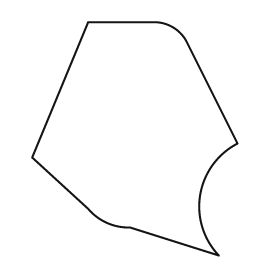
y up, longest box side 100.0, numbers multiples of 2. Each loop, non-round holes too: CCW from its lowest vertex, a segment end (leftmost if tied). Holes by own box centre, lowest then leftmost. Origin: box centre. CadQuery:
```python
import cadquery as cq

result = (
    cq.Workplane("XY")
    .moveTo(36.0, -50.0)
    .threePointArc((28.0, -24.0), (44.0, -2.0))
    .lineTo(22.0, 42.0)
    .threePointArc((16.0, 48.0), (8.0, 50.0))
    .lineTo(-20.0, 50.0)
    .lineTo(-44.0, -8.0)
    .lineTo(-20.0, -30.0)
    .threePointArc((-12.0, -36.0), (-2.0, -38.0))
    .close()
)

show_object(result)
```